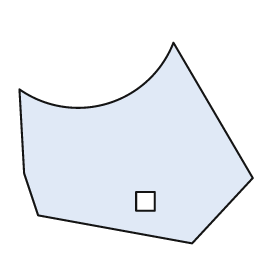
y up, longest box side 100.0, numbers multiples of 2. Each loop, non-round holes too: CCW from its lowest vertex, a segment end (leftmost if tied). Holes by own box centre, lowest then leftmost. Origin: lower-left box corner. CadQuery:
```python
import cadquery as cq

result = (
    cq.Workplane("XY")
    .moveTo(74.0, 0.0)
    .lineTo(100.0, 28.0)
    .lineTo(66.0, 86.0)
    .threePointArc((38.0, 60.0), (0.0, 66.0))
    .lineTo(2.0, 30.0)
    .lineTo(8.0, 12.0)
    .close()
    .moveTo(50.0, 14.0)
    .lineTo(58.0, 14.0)
    .lineTo(58.0, 22.0)
    .lineTo(50.0, 22.0)
    .close()
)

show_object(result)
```